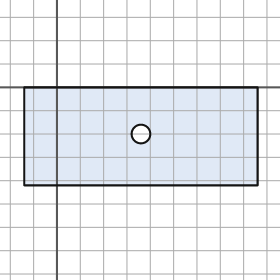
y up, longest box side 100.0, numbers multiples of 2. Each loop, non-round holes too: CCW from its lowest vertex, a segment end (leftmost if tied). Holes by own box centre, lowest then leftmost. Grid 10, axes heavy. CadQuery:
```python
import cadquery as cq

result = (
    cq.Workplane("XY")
    .moveTo(-14.0, -42.0)
    .lineTo(86.0, -42.0)
    .lineTo(86.0, 0.0)
    .lineTo(-14.0, 0.0)
    .close()
    .moveTo(36.0, -20.0)
    .circle(4.0)
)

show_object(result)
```